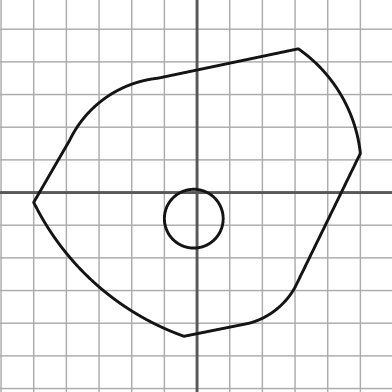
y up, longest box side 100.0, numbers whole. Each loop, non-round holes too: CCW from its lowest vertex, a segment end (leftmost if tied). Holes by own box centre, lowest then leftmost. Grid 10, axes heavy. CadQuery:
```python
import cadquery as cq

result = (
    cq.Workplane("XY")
    .moveTo(-4.0, -44.0)
    .lineTo(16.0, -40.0)
    .threePointArc((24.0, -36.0), (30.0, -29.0))
    .lineTo(50.0, 12.0)
    .threePointArc((44.0, 30.0), (31.0, 44.0))
    .lineTo(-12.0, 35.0)
    .threePointArc((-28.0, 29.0), (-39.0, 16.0))
    .lineTo(-50.0, -3.0)
    .threePointArc((-31.0, -28.0), (-4.0, -44.0))
    .close()
    .moveTo(-1.0, -8.0)
    .circle(9.0)
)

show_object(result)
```